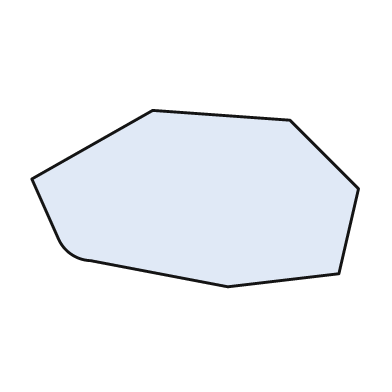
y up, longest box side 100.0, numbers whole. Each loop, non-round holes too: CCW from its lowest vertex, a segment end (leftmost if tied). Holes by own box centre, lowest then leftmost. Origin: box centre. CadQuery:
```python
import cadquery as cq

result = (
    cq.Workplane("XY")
    .moveTo(10.0, -27.0)
    .lineTo(44.0, -23.0)
    .lineTo(50.0, 3.0)
    .lineTo(29.0, 24.0)
    .lineTo(-13.0, 27.0)
    .lineTo(-50.0, 6.0)
    .lineTo(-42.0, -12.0)
    .threePointArc((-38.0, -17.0), (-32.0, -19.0))
    .close()
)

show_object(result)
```